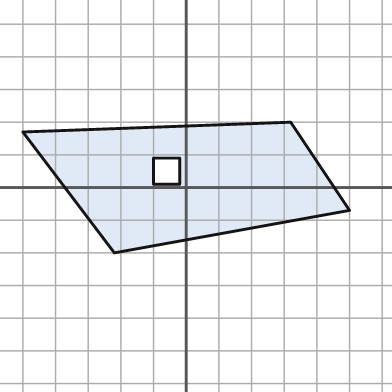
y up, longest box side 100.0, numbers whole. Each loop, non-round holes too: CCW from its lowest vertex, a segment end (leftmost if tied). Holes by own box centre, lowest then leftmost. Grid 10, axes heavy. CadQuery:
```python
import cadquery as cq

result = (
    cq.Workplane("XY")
    .moveTo(-22.0, -20.0)
    .lineTo(50.0, -7.0)
    .lineTo(32.0, 20.0)
    .lineTo(-50.0, 17.0)
    .close()
    .moveTo(-10.0, 1.0)
    .lineTo(-2.0, 1.0)
    .lineTo(-2.0, 9.0)
    .lineTo(-10.0, 9.0)
    .close()
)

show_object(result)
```